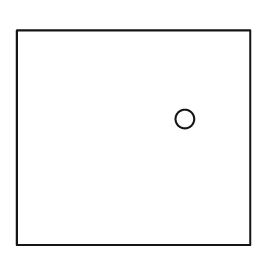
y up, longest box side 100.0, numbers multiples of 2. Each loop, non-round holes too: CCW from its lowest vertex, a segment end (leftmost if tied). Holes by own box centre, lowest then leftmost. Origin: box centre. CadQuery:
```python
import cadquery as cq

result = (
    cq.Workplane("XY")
    .moveTo(-50.0, -46.0)
    .lineTo(50.0, -46.0)
    .lineTo(50.0, 46.0)
    .lineTo(-50.0, 46.0)
    .close()
    .moveTo(22.0, 8.0)
    .circle(4.0)
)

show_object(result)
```